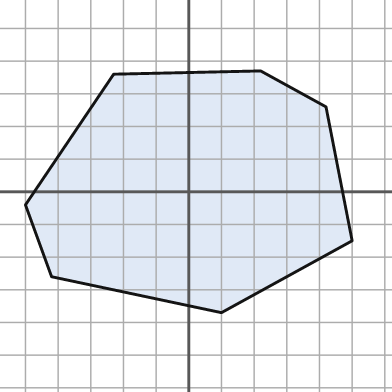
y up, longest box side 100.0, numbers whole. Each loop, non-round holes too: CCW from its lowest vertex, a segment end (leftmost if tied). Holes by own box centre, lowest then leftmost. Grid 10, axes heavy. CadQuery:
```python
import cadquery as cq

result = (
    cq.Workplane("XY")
    .moveTo(10.0, -37.0)
    .lineTo(50.0, -15.0)
    .lineTo(42.0, 26.0)
    .lineTo(22.0, 37.0)
    .lineTo(-23.0, 36.0)
    .lineTo(-50.0, -4.0)
    .lineTo(-42.0, -26.0)
    .close()
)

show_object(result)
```